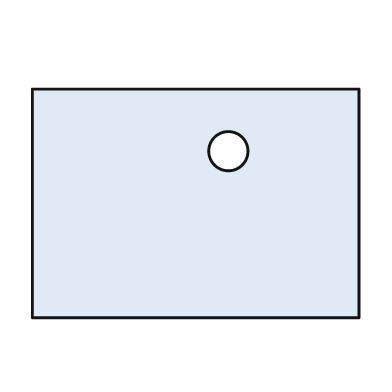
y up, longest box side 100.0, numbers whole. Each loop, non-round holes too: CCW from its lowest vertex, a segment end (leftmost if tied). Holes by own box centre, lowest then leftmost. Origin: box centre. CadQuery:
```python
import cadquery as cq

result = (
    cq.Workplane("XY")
    .moveTo(-50.0, -35.0)
    .lineTo(50.0, -35.0)
    .lineTo(50.0, 35.0)
    .lineTo(-50.0, 35.0)
    .close()
    .moveTo(10.0, 16.0)
    .circle(6.0)
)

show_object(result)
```